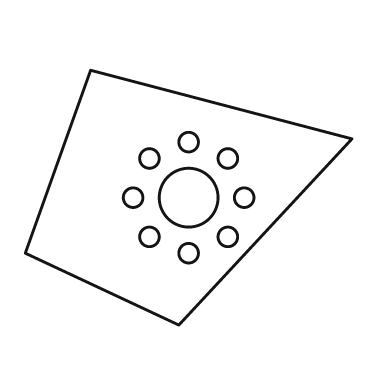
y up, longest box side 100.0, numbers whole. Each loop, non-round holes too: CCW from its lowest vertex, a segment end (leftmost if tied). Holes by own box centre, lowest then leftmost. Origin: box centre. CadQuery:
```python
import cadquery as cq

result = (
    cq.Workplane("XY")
    .moveTo(-3.0, -39.0)
    .lineTo(50.0, 18.0)
    .lineTo(-30.0, 39.0)
    .lineTo(-50.0, -17.0)
    .close()
    .moveTo(0.0, -17.0)
    .circle(3.0)
    .moveTo(-12.0, -12.0)
    .circle(3.0)
    .moveTo(12.0, -12.0)
    .circle(3.0)
    .moveTo(-17.0, 0.0)
    .circle(3.0)
    .moveTo(0.0, 0.0)
    .circle(9.0)
    .moveTo(17.0, 0.0)
    .circle(3.0)
    .moveTo(-12.0, 12.0)
    .circle(3.0)
    .moveTo(12.0, 12.0)
    .circle(3.0)
    .moveTo(0.0, 17.0)
    .circle(3.0)
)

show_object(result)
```